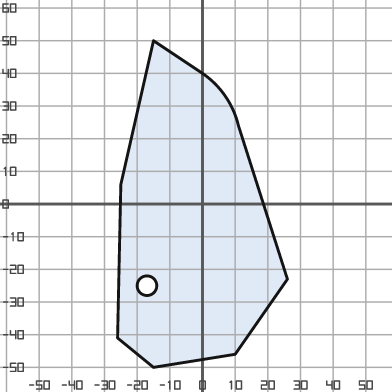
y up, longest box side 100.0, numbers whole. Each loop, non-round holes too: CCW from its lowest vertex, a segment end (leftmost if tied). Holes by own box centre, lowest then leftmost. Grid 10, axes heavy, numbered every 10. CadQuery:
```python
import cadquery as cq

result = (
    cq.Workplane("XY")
    .moveTo(-15.0, -50.0)
    .lineTo(10.0, -46.0)
    .lineTo(26.0, -23.0)
    .lineTo(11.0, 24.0)
    .threePointArc((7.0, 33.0), (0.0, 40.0))
    .lineTo(-15.0, 50.0)
    .lineTo(-25.0, 6.0)
    .lineTo(-26.0, -41.0)
    .close()
    .moveTo(-17.0, -25.0)
    .circle(3.0)
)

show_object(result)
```